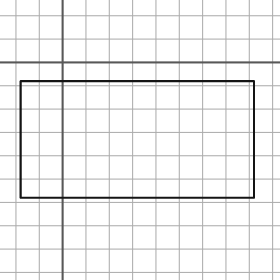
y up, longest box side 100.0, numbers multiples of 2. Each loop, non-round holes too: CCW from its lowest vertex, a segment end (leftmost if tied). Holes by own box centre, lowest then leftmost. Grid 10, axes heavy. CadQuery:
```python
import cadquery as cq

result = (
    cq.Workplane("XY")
    .moveTo(-18.0, -58.0)
    .lineTo(82.0, -58.0)
    .lineTo(82.0, -8.0)
    .lineTo(-18.0, -8.0)
    .close()
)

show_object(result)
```